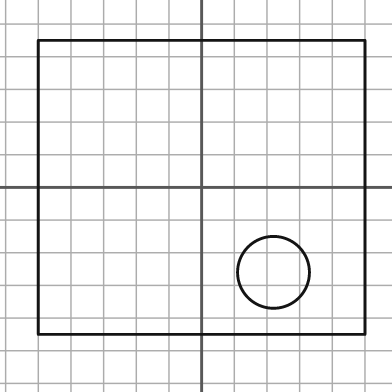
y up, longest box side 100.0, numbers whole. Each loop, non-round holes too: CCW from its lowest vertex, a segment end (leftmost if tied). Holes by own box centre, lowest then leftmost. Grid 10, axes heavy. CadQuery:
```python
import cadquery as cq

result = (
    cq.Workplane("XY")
    .moveTo(-50.0, -45.0)
    .lineTo(50.0, -45.0)
    .lineTo(50.0, 45.0)
    .lineTo(-50.0, 45.0)
    .close()
    .moveTo(22.0, -26.0)
    .circle(11.0)
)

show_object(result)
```